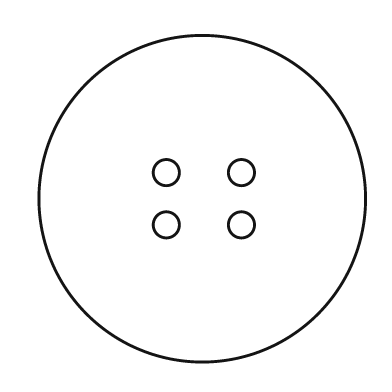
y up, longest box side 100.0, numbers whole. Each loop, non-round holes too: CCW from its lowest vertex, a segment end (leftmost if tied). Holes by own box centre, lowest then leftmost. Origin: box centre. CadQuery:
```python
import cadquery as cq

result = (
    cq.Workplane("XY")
    .moveTo(0.0, 0.0)
    .circle(50.0)
    .moveTo(-11.0, -8.0)
    .circle(4.0)
    .moveTo(12.0, -8.0)
    .circle(4.0)
    .moveTo(-11.0, 8.0)
    .circle(4.0)
    .moveTo(12.0, 8.0)
    .circle(4.0)
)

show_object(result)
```